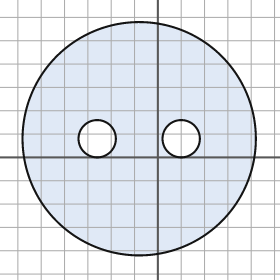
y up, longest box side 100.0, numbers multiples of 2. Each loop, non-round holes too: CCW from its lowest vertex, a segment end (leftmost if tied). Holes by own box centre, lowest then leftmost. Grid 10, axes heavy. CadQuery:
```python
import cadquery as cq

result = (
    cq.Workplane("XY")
    .moveTo(-8.0, 8.0)
    .circle(50.0)
    .moveTo(-26.0, 8.0)
    .circle(8.0)
    .moveTo(10.0, 8.0)
    .circle(8.0)
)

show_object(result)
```